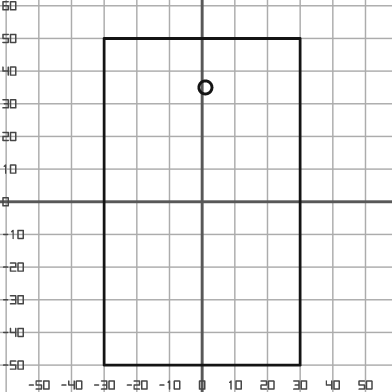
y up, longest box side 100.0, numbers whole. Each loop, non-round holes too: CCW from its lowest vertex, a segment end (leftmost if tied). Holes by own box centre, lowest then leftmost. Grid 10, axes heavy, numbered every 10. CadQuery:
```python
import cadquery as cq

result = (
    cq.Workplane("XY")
    .moveTo(-30.0, -50.0)
    .lineTo(30.0, -50.0)
    .lineTo(30.0, 50.0)
    .lineTo(-30.0, 50.0)
    .close()
    .moveTo(1.0, 35.0)
    .circle(2.0)
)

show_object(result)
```